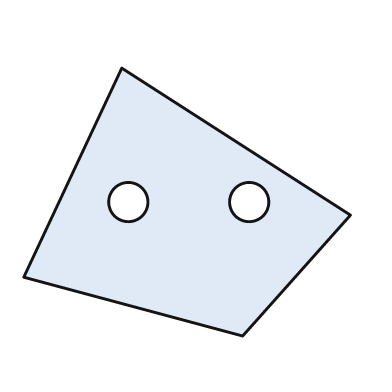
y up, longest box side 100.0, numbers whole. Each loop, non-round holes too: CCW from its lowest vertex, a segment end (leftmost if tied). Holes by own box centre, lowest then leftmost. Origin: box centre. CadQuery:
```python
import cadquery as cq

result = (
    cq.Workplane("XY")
    .moveTo(17.0, -41.0)
    .lineTo(50.0, -4.0)
    .lineTo(-20.0, 41.0)
    .lineTo(-50.0, -23.0)
    .close()
    .moveTo(-18.0, 0.0)
    .circle(6.0)
    .moveTo(19.0, 0.0)
    .circle(6.0)
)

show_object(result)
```